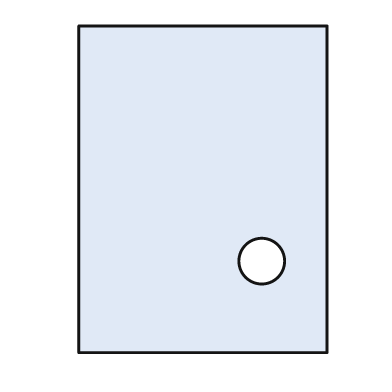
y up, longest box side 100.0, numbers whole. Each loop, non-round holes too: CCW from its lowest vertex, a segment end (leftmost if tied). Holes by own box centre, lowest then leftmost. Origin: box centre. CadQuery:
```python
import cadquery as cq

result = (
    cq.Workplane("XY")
    .moveTo(-38.0, -50.0)
    .lineTo(38.0, -50.0)
    .lineTo(38.0, 50.0)
    .lineTo(-38.0, 50.0)
    .close()
    .moveTo(18.0, -22.0)
    .circle(7.0)
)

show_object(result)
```